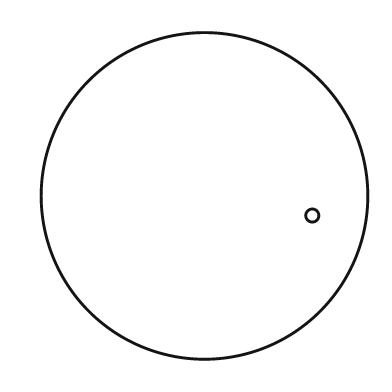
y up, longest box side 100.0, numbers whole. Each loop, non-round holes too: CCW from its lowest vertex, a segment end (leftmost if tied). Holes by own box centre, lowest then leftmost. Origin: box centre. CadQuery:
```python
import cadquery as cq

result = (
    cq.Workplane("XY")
    .moveTo(0.0, 0.0)
    .circle(50.0)
    .moveTo(33.0, -6.0)
    .circle(2.0)
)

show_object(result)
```